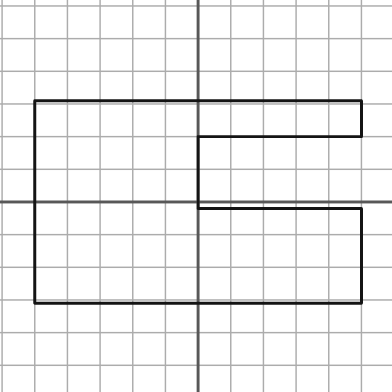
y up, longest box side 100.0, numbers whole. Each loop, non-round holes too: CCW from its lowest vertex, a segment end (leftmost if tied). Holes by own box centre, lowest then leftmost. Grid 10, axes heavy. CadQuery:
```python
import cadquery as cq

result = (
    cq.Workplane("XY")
    .moveTo(-50.0, -31.0)
    .lineTo(50.0, -31.0)
    .lineTo(50.0, -2.0)
    .lineTo(0.0, -2.0)
    .lineTo(0.0, 20.0)
    .lineTo(50.0, 20.0)
    .lineTo(50.0, 31.0)
    .lineTo(-50.0, 31.0)
    .close()
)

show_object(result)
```